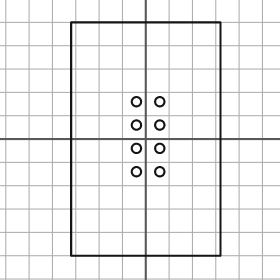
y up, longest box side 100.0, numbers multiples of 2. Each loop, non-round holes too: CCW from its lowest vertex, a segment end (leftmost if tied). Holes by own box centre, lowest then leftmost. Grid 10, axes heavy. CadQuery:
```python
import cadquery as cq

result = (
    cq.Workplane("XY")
    .moveTo(-32.0, -50.0)
    .lineTo(32.0, -50.0)
    .lineTo(32.0, 50.0)
    .lineTo(-32.0, 50.0)
    .close()
    .moveTo(-4.0, -14.0)
    .circle(2.0)
    .moveTo(6.0, -14.0)
    .circle(2.0)
    .moveTo(-4.0, -4.0)
    .circle(2.0)
    .moveTo(6.0, -4.0)
    .circle(2.0)
    .moveTo(-4.0, 6.0)
    .circle(2.0)
    .moveTo(6.0, 6.0)
    .circle(2.0)
    .moveTo(-4.0, 16.0)
    .circle(2.0)
    .moveTo(6.0, 16.0)
    .circle(2.0)
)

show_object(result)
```